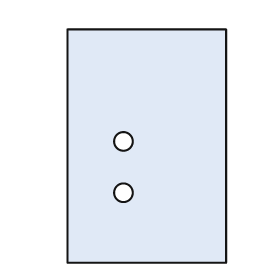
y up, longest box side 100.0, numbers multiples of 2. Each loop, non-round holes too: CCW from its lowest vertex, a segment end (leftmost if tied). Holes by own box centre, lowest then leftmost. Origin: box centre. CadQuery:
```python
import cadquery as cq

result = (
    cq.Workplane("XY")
    .moveTo(-34.0, -50.0)
    .lineTo(34.0, -50.0)
    .lineTo(34.0, 50.0)
    .lineTo(-34.0, 50.0)
    .close()
    .moveTo(-10.0, -20.0)
    .circle(4.0)
    .moveTo(-10.0, 2.0)
    .circle(4.0)
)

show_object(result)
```